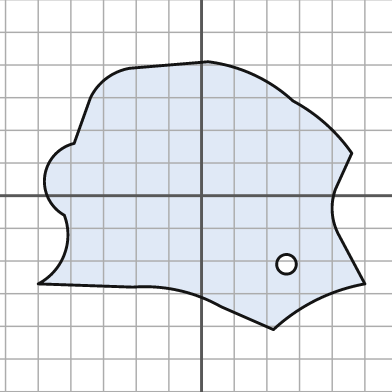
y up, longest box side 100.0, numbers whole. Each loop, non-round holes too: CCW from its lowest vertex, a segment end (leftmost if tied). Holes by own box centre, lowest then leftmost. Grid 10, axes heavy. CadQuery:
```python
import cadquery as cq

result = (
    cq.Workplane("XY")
    .moveTo(22.0, -41.0)
    .threePointArc((35.0, -32.0), (50.0, -27.0))
    .lineTo(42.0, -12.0)
    .threePointArc((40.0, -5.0), (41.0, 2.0))
    .lineTo(46.0, 13.0)
    .threePointArc((38.0, 22.0), (28.0, 29.0))
    .threePointArc((16.0, 37.0), (2.0, 41.0))
    .lineTo(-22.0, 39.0)
    .threePointArc((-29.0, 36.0), (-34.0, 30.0))
    .lineTo(-39.0, 16.0)
    .threePointArc((-48.0, 6.0), (-42.0, -6.0))
    .threePointArc((-42.0, -18.0), (-50.0, -27.0))
    .lineTo(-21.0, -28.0)
    .threePointArc((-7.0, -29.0), (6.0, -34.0))
    .close()
    .moveTo(26.0, -21.0)
    .circle(3.0)
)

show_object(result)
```